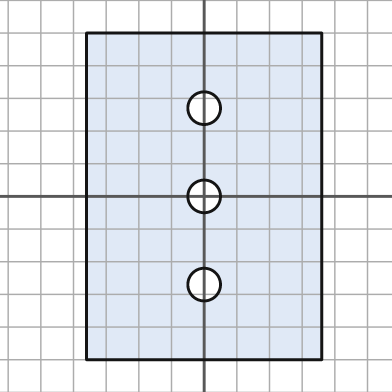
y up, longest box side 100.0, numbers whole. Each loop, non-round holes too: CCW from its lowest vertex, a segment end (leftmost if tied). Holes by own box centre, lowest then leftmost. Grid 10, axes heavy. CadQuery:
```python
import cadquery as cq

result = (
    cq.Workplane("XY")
    .moveTo(-36.0, -50.0)
    .lineTo(36.0, -50.0)
    .lineTo(36.0, 50.0)
    .lineTo(-36.0, 50.0)
    .close()
    .moveTo(0.0, -27.0)
    .circle(5.0)
    .moveTo(0.0, 0.0)
    .circle(5.0)
    .moveTo(0.0, 27.0)
    .circle(5.0)
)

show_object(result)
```